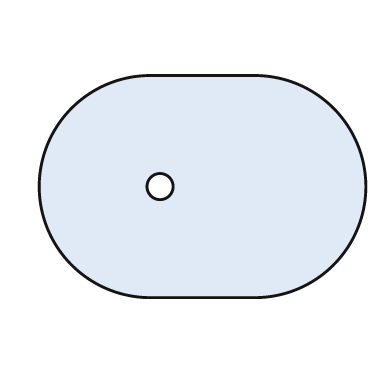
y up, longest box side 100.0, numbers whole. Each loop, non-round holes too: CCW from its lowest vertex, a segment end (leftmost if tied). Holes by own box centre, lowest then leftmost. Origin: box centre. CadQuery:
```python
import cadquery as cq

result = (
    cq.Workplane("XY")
    .moveTo(-16.0, -34.0)
    .lineTo(16.0, -34.0)
    .threePointArc((50.0, 0.0), (16.0, 34.0))
    .lineTo(-16.0, 34.0)
    .threePointArc((-50.0, 0.0), (-16.0, -34.0))
    .close()
    .moveTo(-13.0, 0.0)
    .circle(4.0)
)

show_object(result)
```